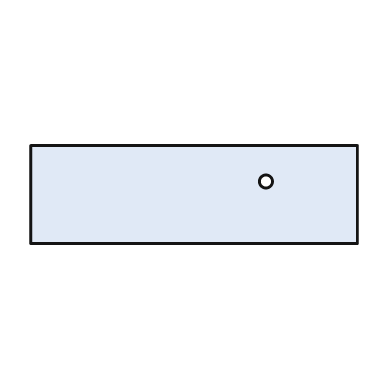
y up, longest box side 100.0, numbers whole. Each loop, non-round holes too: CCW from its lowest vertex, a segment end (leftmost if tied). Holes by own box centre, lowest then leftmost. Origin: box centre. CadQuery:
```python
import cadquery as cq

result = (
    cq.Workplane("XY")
    .moveTo(-50.0, -15.0)
    .lineTo(50.0, -15.0)
    .lineTo(50.0, 15.0)
    .lineTo(-50.0, 15.0)
    .close()
    .moveTo(22.0, 4.0)
    .circle(2.0)
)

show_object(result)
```